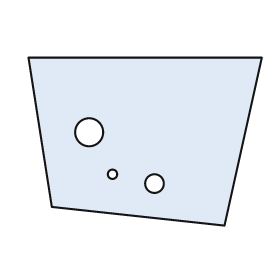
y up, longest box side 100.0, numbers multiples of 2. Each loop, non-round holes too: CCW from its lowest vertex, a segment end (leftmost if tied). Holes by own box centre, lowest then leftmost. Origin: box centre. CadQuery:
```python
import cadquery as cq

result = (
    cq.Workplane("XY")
    .moveTo(34.0, -36.0)
    .lineTo(50.0, 36.0)
    .lineTo(-50.0, 36.0)
    .lineTo(-40.0, -28.0)
    .close()
    .moveTo(4.0, -18.0)
    .circle(4.0)
    .moveTo(-14.0, -14.0)
    .circle(2.0)
    .moveTo(-24.0, 4.0)
    .circle(6.0)
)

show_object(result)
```